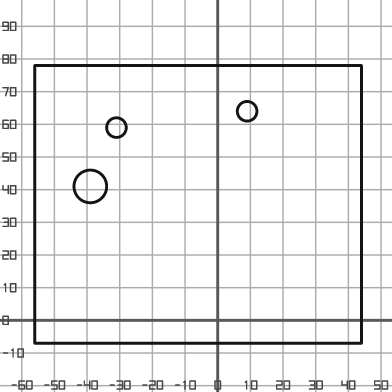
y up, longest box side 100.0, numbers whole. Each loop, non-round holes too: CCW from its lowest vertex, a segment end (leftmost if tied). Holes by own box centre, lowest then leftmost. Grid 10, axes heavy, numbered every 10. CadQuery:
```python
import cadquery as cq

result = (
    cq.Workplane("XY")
    .moveTo(-56.0, -7.0)
    .lineTo(44.0, -7.0)
    .lineTo(44.0, 78.0)
    .lineTo(-56.0, 78.0)
    .close()
    .moveTo(-39.0, 41.0)
    .circle(5.0)
    .moveTo(-31.0, 59.0)
    .circle(3.0)
    .moveTo(9.0, 64.0)
    .circle(3.0)
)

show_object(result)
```